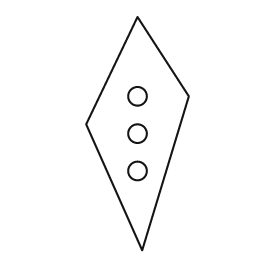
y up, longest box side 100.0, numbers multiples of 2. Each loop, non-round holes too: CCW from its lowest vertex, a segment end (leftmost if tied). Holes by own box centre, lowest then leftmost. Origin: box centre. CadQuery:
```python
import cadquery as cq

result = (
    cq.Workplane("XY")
    .moveTo(2.0, -50.0)
    .lineTo(22.0, 16.0)
    .lineTo(0.0, 50.0)
    .lineTo(-22.0, 4.0)
    .close()
    .moveTo(0.0, -16.0)
    .circle(4.0)
    .moveTo(0.0, 0.0)
    .circle(4.0)
    .moveTo(0.0, 16.0)
    .circle(4.0)
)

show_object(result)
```